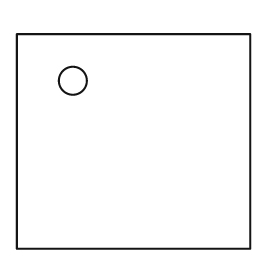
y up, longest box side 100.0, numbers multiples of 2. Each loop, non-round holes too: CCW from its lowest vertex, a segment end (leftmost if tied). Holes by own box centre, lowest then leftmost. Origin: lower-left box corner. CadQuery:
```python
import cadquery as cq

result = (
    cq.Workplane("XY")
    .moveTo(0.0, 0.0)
    .lineTo(100.0, 0.0)
    .lineTo(100.0, 92.0)
    .lineTo(0.0, 92.0)
    .close()
    .moveTo(24.0, 72.0)
    .circle(6.0)
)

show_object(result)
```